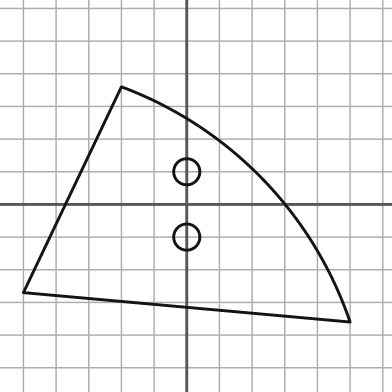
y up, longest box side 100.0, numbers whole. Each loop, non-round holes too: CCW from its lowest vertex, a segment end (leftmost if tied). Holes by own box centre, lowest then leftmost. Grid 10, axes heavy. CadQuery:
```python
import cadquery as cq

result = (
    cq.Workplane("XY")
    .moveTo(50.0, -36.0)
    .threePointArc((23.0, 8.0), (-20.0, 36.0))
    .lineTo(-50.0, -27.0)
    .close()
    .moveTo(0.0, -10.0)
    .circle(4.0)
    .moveTo(0.0, 10.0)
    .circle(4.0)
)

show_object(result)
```